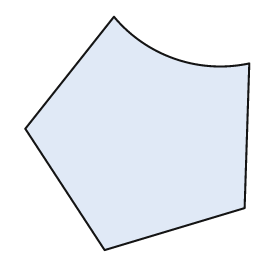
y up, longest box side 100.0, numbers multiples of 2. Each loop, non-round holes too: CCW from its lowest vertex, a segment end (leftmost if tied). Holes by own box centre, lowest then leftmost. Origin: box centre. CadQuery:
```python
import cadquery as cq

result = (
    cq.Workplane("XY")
    .moveTo(-14.0, -50.0)
    .lineTo(46.0, -32.0)
    .lineTo(48.0, 30.0)
    .threePointArc((16.0, 32.0), (-10.0, 50.0))
    .lineTo(-48.0, 2.0)
    .close()
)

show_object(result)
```